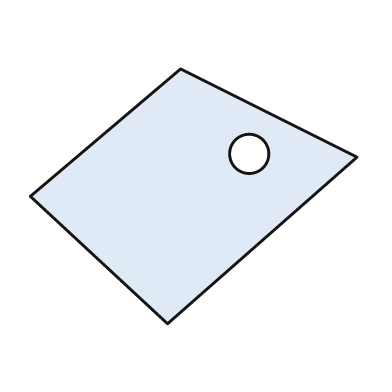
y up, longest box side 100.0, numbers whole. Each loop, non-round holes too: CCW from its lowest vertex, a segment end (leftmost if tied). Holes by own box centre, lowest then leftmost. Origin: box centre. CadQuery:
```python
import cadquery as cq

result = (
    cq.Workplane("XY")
    .moveTo(-8.0, -39.0)
    .lineTo(50.0, 12.0)
    .lineTo(-4.0, 39.0)
    .lineTo(-50.0, 0.0)
    .close()
    .moveTo(17.0, 13.0)
    .circle(6.0)
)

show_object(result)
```